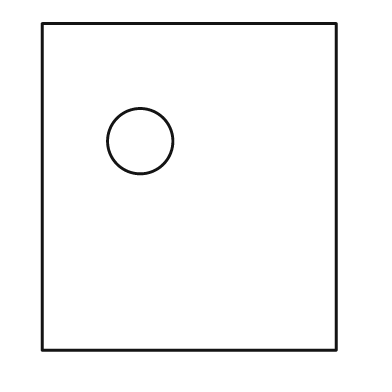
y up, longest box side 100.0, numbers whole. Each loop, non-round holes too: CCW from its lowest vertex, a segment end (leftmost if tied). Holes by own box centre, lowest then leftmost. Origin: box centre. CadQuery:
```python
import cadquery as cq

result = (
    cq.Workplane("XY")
    .moveTo(-45.0, -50.0)
    .lineTo(45.0, -50.0)
    .lineTo(45.0, 50.0)
    .lineTo(-45.0, 50.0)
    .close()
    .moveTo(-15.0, 14.0)
    .circle(10.0)
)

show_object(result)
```